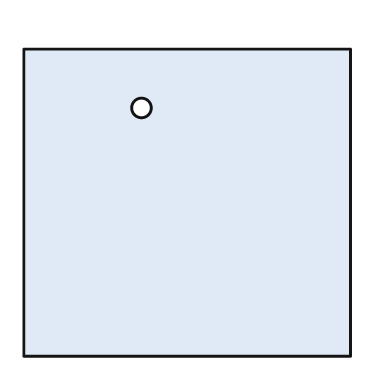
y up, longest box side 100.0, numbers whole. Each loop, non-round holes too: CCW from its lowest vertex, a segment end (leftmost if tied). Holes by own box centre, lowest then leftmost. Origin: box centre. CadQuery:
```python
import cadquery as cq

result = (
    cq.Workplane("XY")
    .moveTo(-50.0, -47.0)
    .lineTo(50.0, -47.0)
    .lineTo(50.0, 47.0)
    .lineTo(-50.0, 47.0)
    .close()
    .moveTo(-14.0, 29.0)
    .circle(3.0)
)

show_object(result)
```